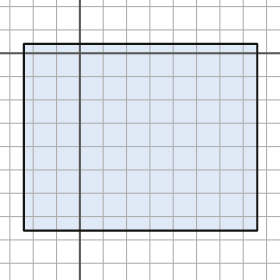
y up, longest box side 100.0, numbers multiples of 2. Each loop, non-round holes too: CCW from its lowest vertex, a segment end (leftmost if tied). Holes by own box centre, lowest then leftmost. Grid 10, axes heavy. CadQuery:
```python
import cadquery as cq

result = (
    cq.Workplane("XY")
    .moveTo(-24.0, -76.0)
    .lineTo(76.0, -76.0)
    .lineTo(76.0, 4.0)
    .lineTo(-24.0, 4.0)
    .close()
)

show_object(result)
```